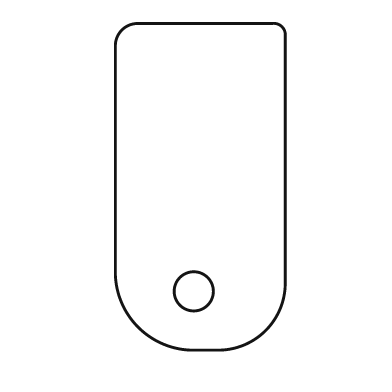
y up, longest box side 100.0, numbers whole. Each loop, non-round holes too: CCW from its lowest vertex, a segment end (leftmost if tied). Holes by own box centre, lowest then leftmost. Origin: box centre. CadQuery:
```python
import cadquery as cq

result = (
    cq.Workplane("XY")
    .moveTo(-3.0, -50.0)
    .lineTo(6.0, -50.0)
    .threePointArc((20.0, -44.0), (26.0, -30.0))
    .lineTo(26.0, 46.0)
    .threePointArc((25.0, 49.0), (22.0, 50.0))
    .lineTo(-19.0, 50.0)
    .threePointArc((-24.0, 48.0), (-26.0, 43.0))
    .lineTo(-26.0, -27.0)
    .threePointArc((-19.0, -43.0), (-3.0, -50.0))
    .close()
    .moveTo(-2.0, -32.0)
    .circle(6.0)
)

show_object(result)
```